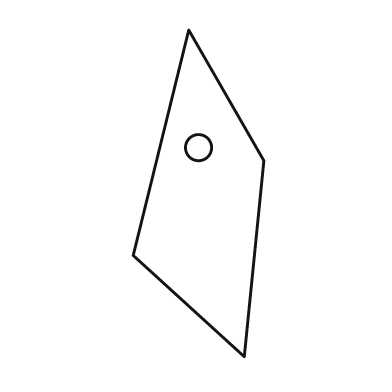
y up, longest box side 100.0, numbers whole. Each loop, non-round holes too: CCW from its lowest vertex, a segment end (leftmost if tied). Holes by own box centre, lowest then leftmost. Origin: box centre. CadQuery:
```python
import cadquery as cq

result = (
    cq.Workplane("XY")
    .moveTo(14.0, -50.0)
    .lineTo(20.0, 10.0)
    .lineTo(-3.0, 50.0)
    .lineTo(-20.0, -19.0)
    .close()
    .moveTo(0.0, 14.0)
    .circle(4.0)
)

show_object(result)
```